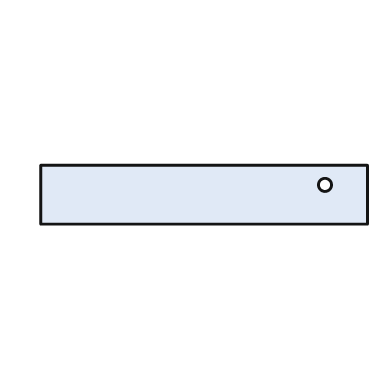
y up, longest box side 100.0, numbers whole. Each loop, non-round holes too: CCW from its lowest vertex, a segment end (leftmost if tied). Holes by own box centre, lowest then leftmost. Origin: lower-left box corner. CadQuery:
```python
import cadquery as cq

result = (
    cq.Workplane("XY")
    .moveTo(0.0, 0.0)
    .lineTo(100.0, 0.0)
    .lineTo(100.0, 18.0)
    .lineTo(0.0, 18.0)
    .close()
    .moveTo(87.0, 12.0)
    .circle(2.0)
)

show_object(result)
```